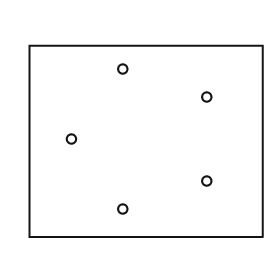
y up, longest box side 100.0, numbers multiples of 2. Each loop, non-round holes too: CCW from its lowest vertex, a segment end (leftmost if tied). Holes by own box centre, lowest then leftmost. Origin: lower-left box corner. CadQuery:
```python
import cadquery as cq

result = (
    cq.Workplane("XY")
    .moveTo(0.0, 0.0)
    .lineTo(100.0, 0.0)
    .lineTo(100.0, 82.0)
    .lineTo(0.0, 82.0)
    .close()
    .moveTo(40.0, 12.0)
    .circle(2.0)
    .moveTo(76.0, 24.0)
    .circle(2.0)
    .moveTo(18.0, 42.0)
    .circle(2.0)
    .moveTo(76.0, 60.0)
    .circle(2.0)
    .moveTo(40.0, 72.0)
    .circle(2.0)
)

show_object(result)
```